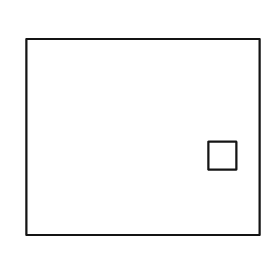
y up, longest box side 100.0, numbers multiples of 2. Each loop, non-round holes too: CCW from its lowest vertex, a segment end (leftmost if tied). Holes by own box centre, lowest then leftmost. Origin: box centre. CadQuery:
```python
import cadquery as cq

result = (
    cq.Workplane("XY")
    .moveTo(-50.0, -42.0)
    .lineTo(50.0, -42.0)
    .lineTo(50.0, 42.0)
    .lineTo(-50.0, 42.0)
    .close()
    .moveTo(28.0, -14.0)
    .lineTo(40.0, -14.0)
    .lineTo(40.0, -2.0)
    .lineTo(28.0, -2.0)
    .close()
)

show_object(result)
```